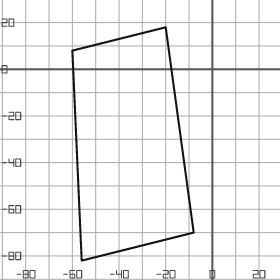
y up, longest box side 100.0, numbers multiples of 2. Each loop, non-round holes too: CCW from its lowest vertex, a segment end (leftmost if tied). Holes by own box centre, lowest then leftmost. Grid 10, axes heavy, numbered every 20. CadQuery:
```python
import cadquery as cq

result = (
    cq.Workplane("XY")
    .moveTo(-56.0, -82.0)
    .lineTo(-8.0, -70.0)
    .lineTo(-20.0, 18.0)
    .lineTo(-60.0, 8.0)
    .close()
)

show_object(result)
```